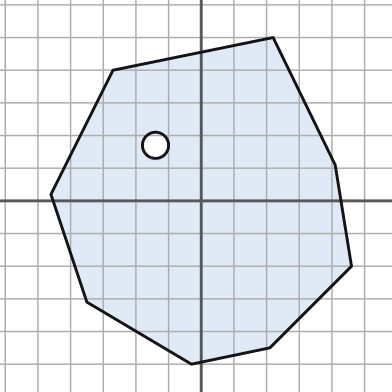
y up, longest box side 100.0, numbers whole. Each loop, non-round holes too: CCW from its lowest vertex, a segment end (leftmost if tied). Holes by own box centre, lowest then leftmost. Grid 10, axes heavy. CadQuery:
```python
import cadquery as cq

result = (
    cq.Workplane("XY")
    .moveTo(-3.0, -50.0)
    .lineTo(21.0, -45.0)
    .lineTo(46.0, -20.0)
    .lineTo(41.0, 11.0)
    .lineTo(22.0, 50.0)
    .lineTo(-27.0, 40.0)
    .lineTo(-46.0, 2.0)
    .lineTo(-35.0, -31.0)
    .close()
    .moveTo(-14.0, 17.0)
    .circle(4.0)
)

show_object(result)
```